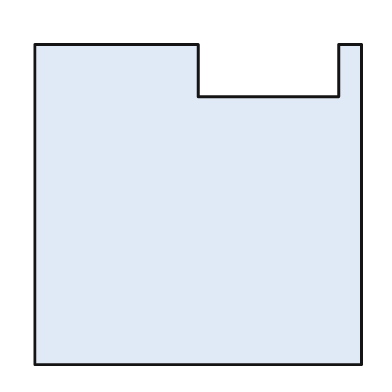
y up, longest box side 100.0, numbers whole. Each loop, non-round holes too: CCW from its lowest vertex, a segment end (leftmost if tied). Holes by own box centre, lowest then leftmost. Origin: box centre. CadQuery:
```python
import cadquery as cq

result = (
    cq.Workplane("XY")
    .moveTo(-50.0, -49.0)
    .lineTo(50.0, -49.0)
    .lineTo(50.0, 49.0)
    .lineTo(43.0, 49.0)
    .lineTo(43.0, 33.0)
    .lineTo(0.0, 33.0)
    .lineTo(0.0, 49.0)
    .lineTo(-50.0, 49.0)
    .close()
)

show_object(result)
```